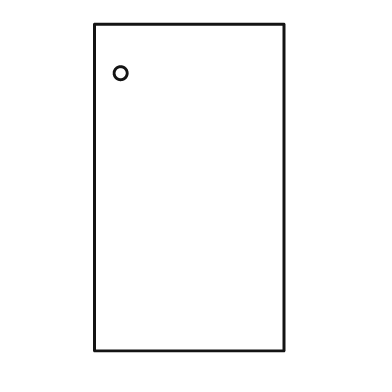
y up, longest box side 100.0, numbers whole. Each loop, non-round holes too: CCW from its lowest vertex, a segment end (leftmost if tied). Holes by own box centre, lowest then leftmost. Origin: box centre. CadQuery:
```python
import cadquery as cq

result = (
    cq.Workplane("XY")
    .moveTo(-29.0, -50.0)
    .lineTo(29.0, -50.0)
    .lineTo(29.0, 50.0)
    .lineTo(-29.0, 50.0)
    .close()
    .moveTo(-21.0, 35.0)
    .circle(2.0)
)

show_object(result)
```